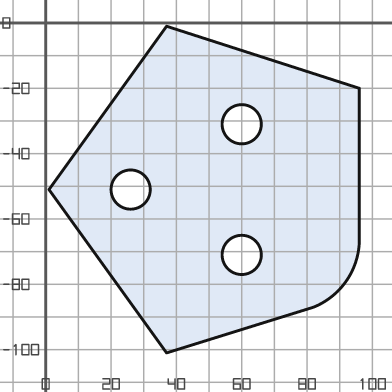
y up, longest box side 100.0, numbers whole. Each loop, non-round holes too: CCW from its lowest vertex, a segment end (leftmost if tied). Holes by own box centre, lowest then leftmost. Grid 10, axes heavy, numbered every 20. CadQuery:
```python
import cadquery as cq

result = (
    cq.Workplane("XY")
    .moveTo(37.0, -101.0)
    .lineTo(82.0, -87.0)
    .threePointArc((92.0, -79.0), (96.0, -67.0))
    .lineTo(96.0, -20.0)
    .lineTo(37.0, -1.0)
    .lineTo(1.0, -51.0)
    .close()
    .moveTo(60.0, -71.0)
    .circle(6.0)
    .moveTo(26.0, -51.0)
    .circle(6.0)
    .moveTo(60.0, -31.0)
    .circle(6.0)
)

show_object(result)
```